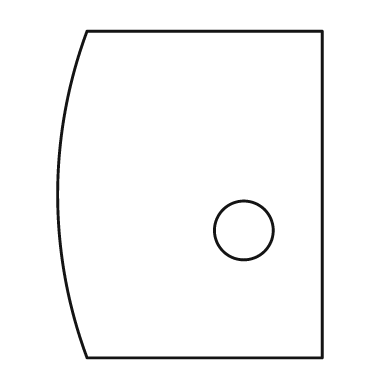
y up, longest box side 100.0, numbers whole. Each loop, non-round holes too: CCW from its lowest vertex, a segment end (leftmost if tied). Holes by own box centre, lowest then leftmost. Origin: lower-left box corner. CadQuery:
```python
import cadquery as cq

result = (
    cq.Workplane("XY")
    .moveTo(9.0, 0.0)
    .lineTo(81.0, 0.0)
    .lineTo(81.0, 100.0)
    .lineTo(9.0, 100.0)
    .threePointArc((0.0, 50.0), (9.0, 0.0))
    .close()
    .moveTo(57.0, 39.0)
    .circle(9.0)
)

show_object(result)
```